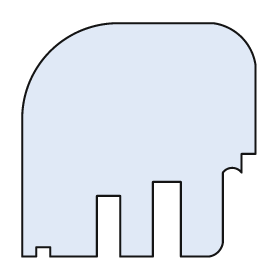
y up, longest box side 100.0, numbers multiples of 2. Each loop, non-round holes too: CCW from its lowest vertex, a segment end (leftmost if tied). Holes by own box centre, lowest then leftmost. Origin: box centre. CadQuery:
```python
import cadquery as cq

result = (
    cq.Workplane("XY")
    .moveTo(-50.0, -50.0)
    .lineTo(-44.0, -50.0)
    .lineTo(-44.0, -46.0)
    .lineTo(-38.0, -46.0)
    .lineTo(-38.0, -50.0)
    .lineTo(-18.0, -50.0)
    .lineTo(-18.0, -24.0)
    .lineTo(-8.0, -24.0)
    .lineTo(-8.0, -50.0)
    .lineTo(6.0, -50.0)
    .lineTo(6.0, -18.0)
    .lineTo(18.0, -18.0)
    .lineTo(18.0, -50.0)
    .lineTo(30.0, -50.0)
    .threePointArc((34.0, -48.0), (36.0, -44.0))
    .lineTo(36.0, -14.0)
    .threePointArc((40.0, -12.0), (44.0, -14.0))
    .lineTo(44.0, -6.0)
    .lineTo(50.0, -6.0)
    .lineTo(50.0, 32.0)
    .threePointArc((44.0, 44.0), (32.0, 50.0))
    .lineTo(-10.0, 50.0)
    .threePointArc((-38.0, 38.0), (-50.0, 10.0))
    .close()
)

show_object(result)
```